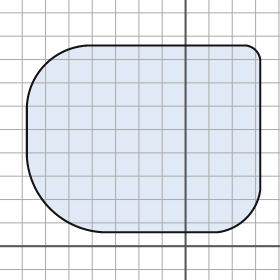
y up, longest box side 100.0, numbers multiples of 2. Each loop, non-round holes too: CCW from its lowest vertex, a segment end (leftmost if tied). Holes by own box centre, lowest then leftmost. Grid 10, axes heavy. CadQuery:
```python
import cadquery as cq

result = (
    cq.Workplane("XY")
    .moveTo(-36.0, 6.0)
    .lineTo(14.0, 6.0)
    .threePointArc((26.0, 12.0), (32.0, 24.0))
    .lineTo(32.0, 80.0)
    .threePointArc((30.0, 84.0), (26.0, 86.0))
    .lineTo(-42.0, 86.0)
    .threePointArc((-60.0, 78.0), (-68.0, 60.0))
    .lineTo(-68.0, 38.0)
    .threePointArc((-58.0, 16.0), (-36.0, 6.0))
    .close()
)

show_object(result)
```